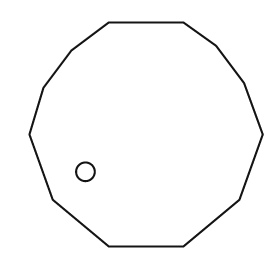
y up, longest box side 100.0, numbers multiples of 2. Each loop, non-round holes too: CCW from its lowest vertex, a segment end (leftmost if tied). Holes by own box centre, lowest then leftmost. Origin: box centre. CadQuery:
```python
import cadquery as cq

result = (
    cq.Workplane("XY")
    .moveTo(-16.0, -48.0)
    .lineTo(16.0, -48.0)
    .lineTo(40.0, -28.0)
    .lineTo(50.0, 0.0)
    .lineTo(42.0, 22.0)
    .lineTo(30.0, 38.0)
    .lineTo(16.0, 48.0)
    .lineTo(-16.0, 48.0)
    .lineTo(-32.0, 36.0)
    .lineTo(-44.0, 20.0)
    .lineTo(-50.0, 0.0)
    .lineTo(-40.0, -28.0)
    .close()
    .moveTo(-26.0, -16.0)
    .circle(4.0)
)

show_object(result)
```